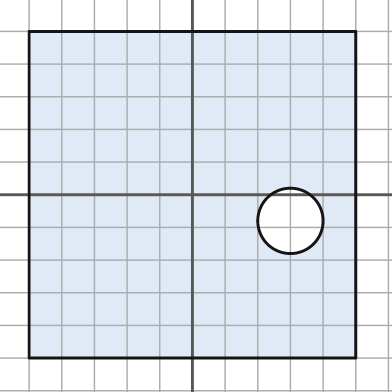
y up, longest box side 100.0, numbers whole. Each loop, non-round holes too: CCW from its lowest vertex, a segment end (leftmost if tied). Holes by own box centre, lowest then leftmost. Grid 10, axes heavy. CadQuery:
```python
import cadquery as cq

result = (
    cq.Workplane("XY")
    .moveTo(-50.0, -50.0)
    .lineTo(50.0, -50.0)
    .lineTo(50.0, 50.0)
    .lineTo(-50.0, 50.0)
    .close()
    .moveTo(30.0, -8.0)
    .circle(10.0)
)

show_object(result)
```